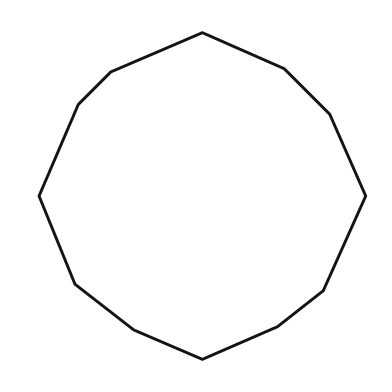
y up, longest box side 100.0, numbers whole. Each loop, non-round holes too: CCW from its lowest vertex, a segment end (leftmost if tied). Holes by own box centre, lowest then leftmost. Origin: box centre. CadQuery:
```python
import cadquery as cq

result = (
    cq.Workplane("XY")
    .moveTo(0.0, -50.0)
    .lineTo(23.0, -40.0)
    .lineTo(37.0, -29.0)
    .lineTo(50.0, 0.0)
    .lineTo(39.0, 25.0)
    .lineTo(25.0, 39.0)
    .lineTo(0.0, 50.0)
    .lineTo(-28.0, 38.0)
    .lineTo(-38.0, 28.0)
    .lineTo(-50.0, 0.0)
    .lineTo(-39.0, -27.0)
    .lineTo(-21.0, -41.0)
    .close()
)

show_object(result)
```